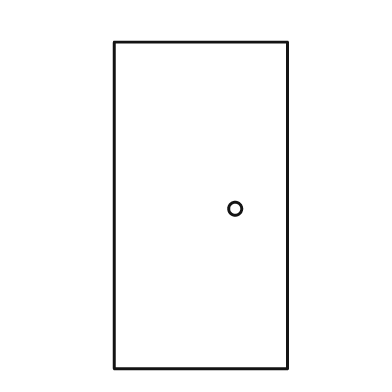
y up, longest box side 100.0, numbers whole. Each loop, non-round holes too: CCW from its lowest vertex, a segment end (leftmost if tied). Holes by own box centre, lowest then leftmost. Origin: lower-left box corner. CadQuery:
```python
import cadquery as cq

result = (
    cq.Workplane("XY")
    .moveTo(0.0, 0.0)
    .lineTo(53.0, 0.0)
    .lineTo(53.0, 100.0)
    .lineTo(0.0, 100.0)
    .close()
    .moveTo(37.0, 49.0)
    .circle(2.0)
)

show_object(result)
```